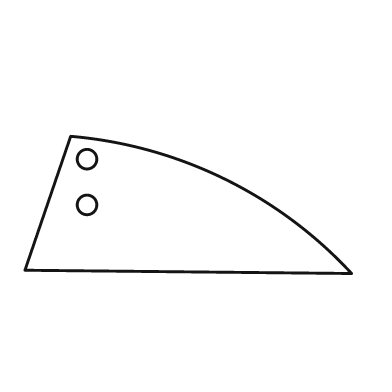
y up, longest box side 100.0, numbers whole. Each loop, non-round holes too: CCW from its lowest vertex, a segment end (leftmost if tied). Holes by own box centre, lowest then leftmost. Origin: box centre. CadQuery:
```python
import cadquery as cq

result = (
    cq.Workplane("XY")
    .moveTo(50.0, -21.0)
    .threePointArc((11.0, 8.0), (-36.0, 21.0))
    .lineTo(-50.0, -20.0)
    .close()
    .moveTo(-31.0, 0.0)
    .circle(3.0)
    .moveTo(-31.0, 14.0)
    .circle(3.0)
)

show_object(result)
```